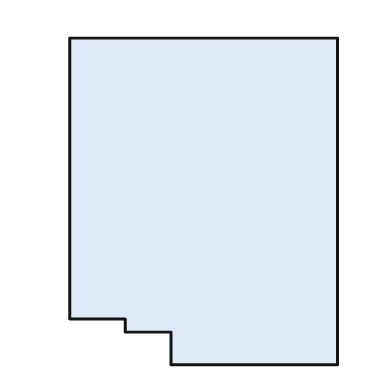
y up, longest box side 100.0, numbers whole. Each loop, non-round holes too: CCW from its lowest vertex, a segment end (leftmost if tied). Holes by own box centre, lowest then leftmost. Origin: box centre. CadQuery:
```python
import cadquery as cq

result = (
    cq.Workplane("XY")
    .moveTo(-10.0, -50.0)
    .lineTo(41.0, -50.0)
    .lineTo(41.0, 50.0)
    .lineTo(-41.0, 50.0)
    .lineTo(-41.0, -36.0)
    .lineTo(-24.0, -36.0)
    .lineTo(-24.0, -40.0)
    .lineTo(-10.0, -40.0)
    .close()
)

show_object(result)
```